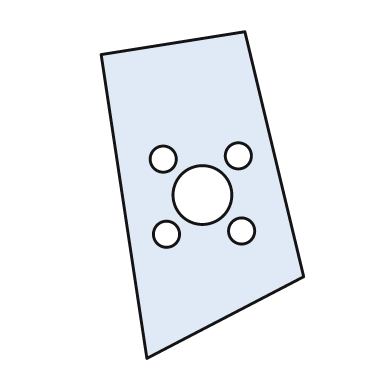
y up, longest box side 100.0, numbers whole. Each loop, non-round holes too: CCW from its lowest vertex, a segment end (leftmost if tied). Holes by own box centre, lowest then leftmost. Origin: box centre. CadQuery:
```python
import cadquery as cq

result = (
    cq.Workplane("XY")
    .moveTo(-17.0, -50.0)
    .lineTo(31.0, -25.0)
    .lineTo(13.0, 50.0)
    .lineTo(-31.0, 43.0)
    .close()
    .moveTo(-11.0, -12.0)
    .circle(4.0)
    .moveTo(12.0, -11.0)
    .circle(4.0)
    .moveTo(0.0, 0.0)
    .circle(9.0)
    .moveTo(-12.0, 11.0)
    .circle(4.0)
    .moveTo(11.0, 12.0)
    .circle(4.0)
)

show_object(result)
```